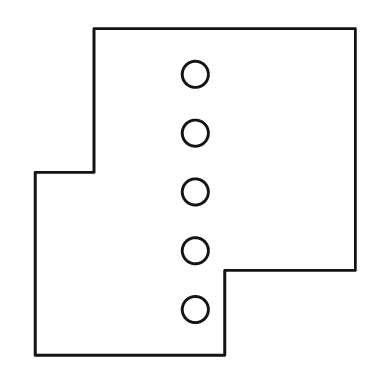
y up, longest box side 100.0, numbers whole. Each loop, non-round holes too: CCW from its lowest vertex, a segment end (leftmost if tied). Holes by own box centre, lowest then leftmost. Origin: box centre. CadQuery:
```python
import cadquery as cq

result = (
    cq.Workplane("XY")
    .moveTo(-49.0, -50.0)
    .lineTo(9.0, -50.0)
    .lineTo(9.0, -24.0)
    .lineTo(49.0, -24.0)
    .lineTo(49.0, 50.0)
    .lineTo(-31.0, 50.0)
    .lineTo(-31.0, 6.0)
    .lineTo(-49.0, 6.0)
    .close()
    .moveTo(0.0, -36.0)
    .circle(4.0)
    .moveTo(0.0, -18.0)
    .circle(4.0)
    .moveTo(0.0, 0.0)
    .circle(4.0)
    .moveTo(0.0, 18.0)
    .circle(4.0)
    .moveTo(0.0, 36.0)
    .circle(4.0)
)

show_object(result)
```